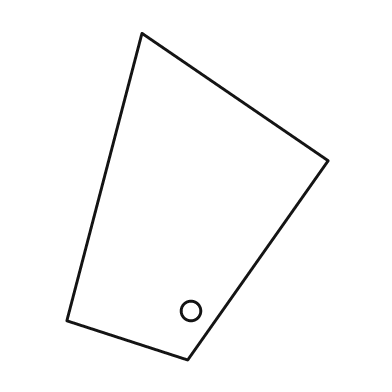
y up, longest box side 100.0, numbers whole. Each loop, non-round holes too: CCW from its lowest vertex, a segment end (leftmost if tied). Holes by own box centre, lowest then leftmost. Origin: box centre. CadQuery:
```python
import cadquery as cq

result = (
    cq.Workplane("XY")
    .moveTo(-3.0, -50.0)
    .lineTo(40.0, 11.0)
    .lineTo(-17.0, 50.0)
    .lineTo(-40.0, -38.0)
    .close()
    .moveTo(-2.0, -35.0)
    .circle(3.0)
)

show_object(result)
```